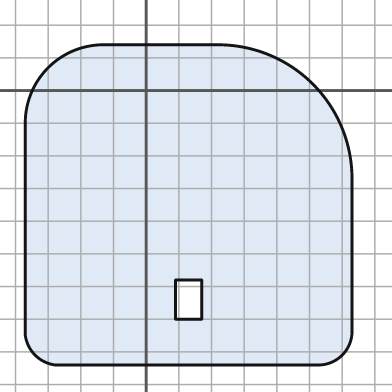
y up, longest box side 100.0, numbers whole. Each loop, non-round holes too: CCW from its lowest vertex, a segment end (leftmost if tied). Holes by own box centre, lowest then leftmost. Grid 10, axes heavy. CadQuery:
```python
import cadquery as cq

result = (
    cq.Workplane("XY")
    .moveTo(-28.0, -84.0)
    .lineTo(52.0, -84.0)
    .threePointArc((60.0, -81.0), (63.0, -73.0))
    .lineTo(63.0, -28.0)
    .threePointArc((51.0, 2.0), (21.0, 14.0))
    .lineTo(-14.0, 14.0)
    .threePointArc((-30.0, 7.0), (-37.0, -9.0))
    .lineTo(-37.0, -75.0)
    .threePointArc((-34.0, -81.0), (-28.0, -84.0))
    .close()
    .moveTo(9.0, -70.0)
    .lineTo(17.0, -70.0)
    .lineTo(17.0, -58.0)
    .lineTo(9.0, -58.0)
    .close()
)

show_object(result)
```